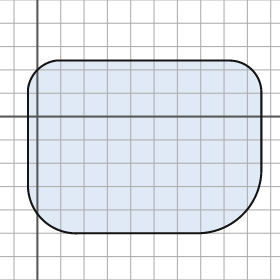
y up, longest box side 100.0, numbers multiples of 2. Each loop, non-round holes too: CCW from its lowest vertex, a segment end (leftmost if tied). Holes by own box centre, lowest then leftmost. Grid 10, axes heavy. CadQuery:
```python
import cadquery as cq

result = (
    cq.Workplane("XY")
    .moveTo(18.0, -50.0)
    .lineTo(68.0, -50.0)
    .threePointArc((88.0, -42.0), (96.0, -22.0))
    .lineTo(96.0, 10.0)
    .threePointArc((92.0, 20.0), (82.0, 24.0))
    .lineTo(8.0, 24.0)
    .threePointArc((0.0, 20.0), (-4.0, 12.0))
    .lineTo(-4.0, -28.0)
    .threePointArc((2.0, -44.0), (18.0, -50.0))
    .close()
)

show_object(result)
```